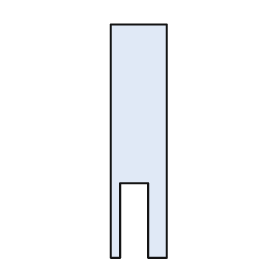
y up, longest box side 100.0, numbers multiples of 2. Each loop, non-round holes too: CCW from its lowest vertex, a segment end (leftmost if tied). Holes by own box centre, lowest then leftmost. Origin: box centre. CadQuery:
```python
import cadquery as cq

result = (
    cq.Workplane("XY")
    .moveTo(-12.0, -50.0)
    .lineTo(-8.0, -50.0)
    .lineTo(-8.0, -18.0)
    .lineTo(4.0, -18.0)
    .lineTo(4.0, -50.0)
    .lineTo(12.0, -50.0)
    .lineTo(12.0, 50.0)
    .lineTo(-12.0, 50.0)
    .close()
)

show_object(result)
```